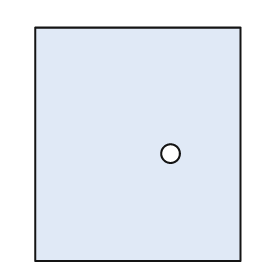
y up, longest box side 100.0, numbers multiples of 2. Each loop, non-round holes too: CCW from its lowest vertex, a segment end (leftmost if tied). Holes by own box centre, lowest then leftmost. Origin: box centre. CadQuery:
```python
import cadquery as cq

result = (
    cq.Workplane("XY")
    .moveTo(-44.0, -50.0)
    .lineTo(44.0, -50.0)
    .lineTo(44.0, 50.0)
    .lineTo(-44.0, 50.0)
    .close()
    .moveTo(14.0, -4.0)
    .circle(4.0)
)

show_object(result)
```